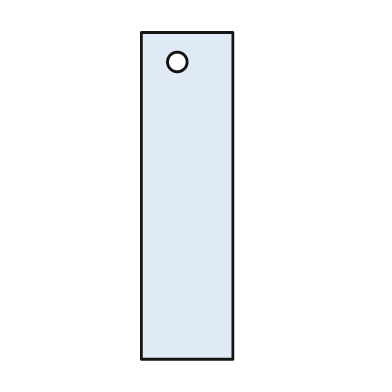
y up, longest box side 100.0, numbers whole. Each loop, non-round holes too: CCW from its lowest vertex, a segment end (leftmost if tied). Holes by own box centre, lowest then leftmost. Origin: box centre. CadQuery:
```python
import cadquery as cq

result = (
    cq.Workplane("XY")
    .moveTo(-14.0, -50.0)
    .lineTo(14.0, -50.0)
    .lineTo(14.0, 50.0)
    .lineTo(-14.0, 50.0)
    .close()
    .moveTo(-3.0, 41.0)
    .circle(3.0)
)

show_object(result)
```